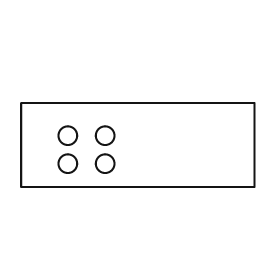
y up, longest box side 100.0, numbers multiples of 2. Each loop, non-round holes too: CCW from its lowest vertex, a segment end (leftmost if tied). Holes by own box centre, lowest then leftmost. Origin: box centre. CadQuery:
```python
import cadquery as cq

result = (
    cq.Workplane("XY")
    .moveTo(-50.0, -18.0)
    .lineTo(50.0, -18.0)
    .lineTo(50.0, 18.0)
    .lineTo(-50.0, 18.0)
    .close()
    .moveTo(-30.0, -8.0)
    .circle(4.0)
    .moveTo(-14.0, -8.0)
    .circle(4.0)
    .moveTo(-30.0, 4.0)
    .circle(4.0)
    .moveTo(-14.0, 4.0)
    .circle(4.0)
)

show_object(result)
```